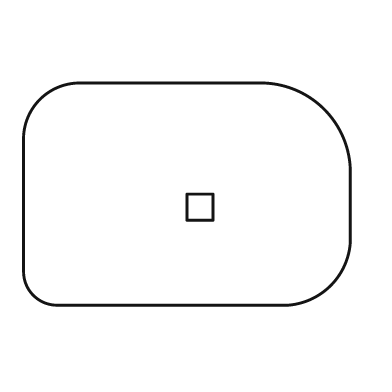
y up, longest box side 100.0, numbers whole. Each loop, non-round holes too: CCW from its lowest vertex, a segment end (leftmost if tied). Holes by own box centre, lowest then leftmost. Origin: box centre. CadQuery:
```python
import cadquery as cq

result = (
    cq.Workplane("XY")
    .moveTo(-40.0, -34.0)
    .lineTo(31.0, -34.0)
    .threePointArc((44.0, -28.0), (50.0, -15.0))
    .lineTo(50.0, 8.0)
    .threePointArc((42.0, 26.0), (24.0, 34.0))
    .lineTo(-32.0, 34.0)
    .threePointArc((-45.0, 29.0), (-50.0, 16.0))
    .lineTo(-50.0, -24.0)
    .threePointArc((-47.0, -31.0), (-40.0, -34.0))
    .close()
    .moveTo(0.0, -8.0)
    .lineTo(8.0, -8.0)
    .lineTo(8.0, 0.0)
    .lineTo(0.0, 0.0)
    .close()
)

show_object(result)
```